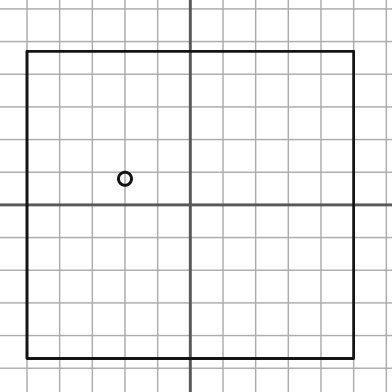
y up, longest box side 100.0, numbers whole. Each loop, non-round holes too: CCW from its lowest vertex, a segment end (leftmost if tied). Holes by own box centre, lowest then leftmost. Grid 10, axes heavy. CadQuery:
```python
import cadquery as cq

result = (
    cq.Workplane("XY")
    .moveTo(-50.0, -47.0)
    .lineTo(50.0, -47.0)
    .lineTo(50.0, 47.0)
    .lineTo(-50.0, 47.0)
    .close()
    .moveTo(-20.0, 8.0)
    .circle(2.0)
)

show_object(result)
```